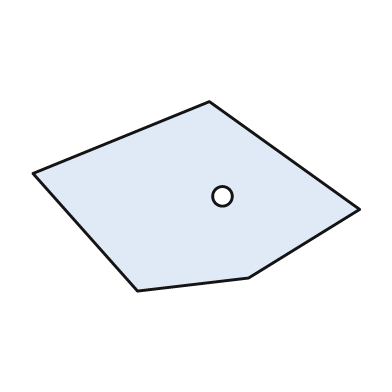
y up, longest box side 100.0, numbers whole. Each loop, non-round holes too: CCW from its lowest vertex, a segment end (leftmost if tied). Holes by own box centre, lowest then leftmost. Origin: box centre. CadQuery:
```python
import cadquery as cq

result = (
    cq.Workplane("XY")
    .moveTo(-18.0, -29.0)
    .lineTo(16.0, -25.0)
    .lineTo(50.0, -4.0)
    .lineTo(4.0, 29.0)
    .lineTo(-50.0, 7.0)
    .close()
    .moveTo(8.0, 0.0)
    .circle(3.0)
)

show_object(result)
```